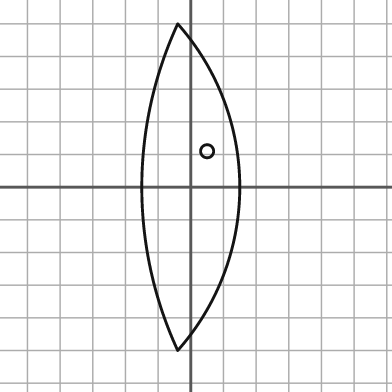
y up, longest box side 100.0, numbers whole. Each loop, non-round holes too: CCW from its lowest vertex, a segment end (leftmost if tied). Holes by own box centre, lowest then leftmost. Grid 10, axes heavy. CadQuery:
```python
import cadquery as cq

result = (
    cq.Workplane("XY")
    .moveTo(-4.0, -50.0)
    .threePointArc((15.0, 0.0), (-4.0, 50.0))
    .threePointArc((-15.0, 0.0), (-4.0, -50.0))
    .close()
    .moveTo(5.0, 11.0)
    .circle(2.0)
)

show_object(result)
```